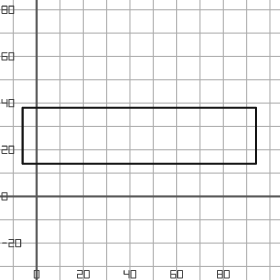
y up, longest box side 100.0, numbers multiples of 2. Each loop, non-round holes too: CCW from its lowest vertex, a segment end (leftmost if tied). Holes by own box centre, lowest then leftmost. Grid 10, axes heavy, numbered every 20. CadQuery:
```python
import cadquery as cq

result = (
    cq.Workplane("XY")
    .moveTo(-6.0, 14.0)
    .lineTo(94.0, 14.0)
    .lineTo(94.0, 38.0)
    .lineTo(-6.0, 38.0)
    .close()
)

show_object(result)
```